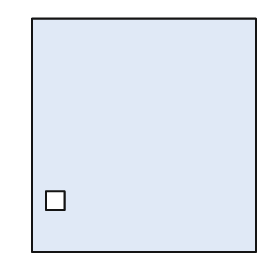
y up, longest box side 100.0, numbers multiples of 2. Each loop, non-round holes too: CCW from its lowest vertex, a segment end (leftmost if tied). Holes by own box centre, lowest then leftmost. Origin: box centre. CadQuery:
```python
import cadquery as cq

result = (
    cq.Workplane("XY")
    .moveTo(-48.0, -50.0)
    .lineTo(48.0, -50.0)
    .lineTo(48.0, 50.0)
    .lineTo(-48.0, 50.0)
    .close()
    .moveTo(-42.0, -32.0)
    .lineTo(-34.0, -32.0)
    .lineTo(-34.0, -24.0)
    .lineTo(-42.0, -24.0)
    .close()
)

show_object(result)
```